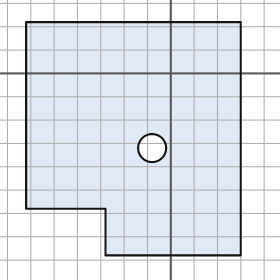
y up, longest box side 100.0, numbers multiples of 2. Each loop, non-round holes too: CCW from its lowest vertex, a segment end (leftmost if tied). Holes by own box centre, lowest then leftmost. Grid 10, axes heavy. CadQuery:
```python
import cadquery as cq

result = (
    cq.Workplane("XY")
    .moveTo(-28.0, -78.0)
    .lineTo(30.0, -78.0)
    .lineTo(30.0, 22.0)
    .lineTo(-62.0, 22.0)
    .lineTo(-62.0, -58.0)
    .lineTo(-28.0, -58.0)
    .close()
    .moveTo(-8.0, -32.0)
    .circle(6.0)
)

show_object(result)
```